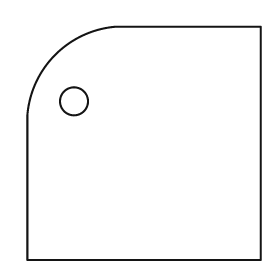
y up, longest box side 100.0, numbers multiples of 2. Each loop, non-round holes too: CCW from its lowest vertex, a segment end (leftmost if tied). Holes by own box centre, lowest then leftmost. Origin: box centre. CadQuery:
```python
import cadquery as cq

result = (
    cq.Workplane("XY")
    .moveTo(-50.0, -50.0)
    .lineTo(50.0, -50.0)
    .lineTo(50.0, 50.0)
    .lineTo(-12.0, 50.0)
    .threePointArc((-38.0, 38.0), (-50.0, 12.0))
    .close()
    .moveTo(-30.0, 18.0)
    .circle(6.0)
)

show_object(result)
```